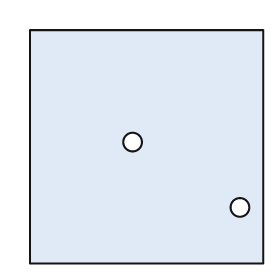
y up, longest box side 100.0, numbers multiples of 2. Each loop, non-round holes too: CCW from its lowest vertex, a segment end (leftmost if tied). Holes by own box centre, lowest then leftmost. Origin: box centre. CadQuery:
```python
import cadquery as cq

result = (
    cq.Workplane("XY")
    .moveTo(-50.0, -50.0)
    .lineTo(50.0, -50.0)
    .lineTo(50.0, 50.0)
    .lineTo(-50.0, 50.0)
    .close()
    .moveTo(40.0, -26.0)
    .circle(4.0)
    .moveTo(-6.0, 2.0)
    .circle(4.0)
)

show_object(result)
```